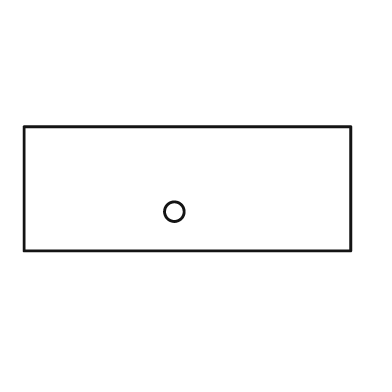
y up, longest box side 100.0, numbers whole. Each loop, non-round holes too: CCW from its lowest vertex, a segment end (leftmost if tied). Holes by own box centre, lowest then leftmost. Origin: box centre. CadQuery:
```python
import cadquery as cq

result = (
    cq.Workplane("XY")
    .moveTo(-50.0, -19.0)
    .lineTo(50.0, -19.0)
    .lineTo(50.0, 19.0)
    .lineTo(-50.0, 19.0)
    .close()
    .moveTo(-4.0, -7.0)
    .circle(3.0)
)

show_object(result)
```